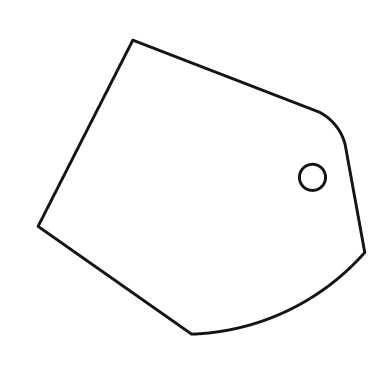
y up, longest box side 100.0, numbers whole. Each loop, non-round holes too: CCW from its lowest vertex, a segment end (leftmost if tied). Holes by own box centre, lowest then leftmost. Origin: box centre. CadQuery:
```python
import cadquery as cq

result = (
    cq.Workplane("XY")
    .moveTo(-3.0, -45.0)
    .threePointArc((26.0, -38.0), (50.0, -20.0))
    .lineTo(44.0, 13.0)
    .threePointArc((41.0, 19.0), (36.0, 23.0))
    .lineTo(-21.0, 45.0)
    .lineTo(-50.0, -12.0)
    .close()
    .moveTo(34.0, 3.0)
    .circle(4.0)
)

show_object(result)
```